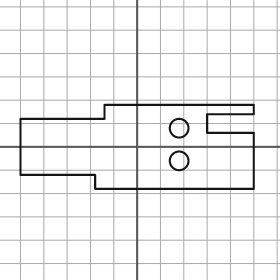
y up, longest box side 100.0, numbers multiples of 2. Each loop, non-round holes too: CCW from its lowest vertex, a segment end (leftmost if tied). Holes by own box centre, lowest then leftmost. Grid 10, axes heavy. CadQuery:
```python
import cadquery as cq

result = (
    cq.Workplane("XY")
    .moveTo(-18.0, -18.0)
    .lineTo(50.0, -18.0)
    .lineTo(50.0, 6.0)
    .lineTo(30.0, 6.0)
    .lineTo(30.0, 14.0)
    .lineTo(50.0, 14.0)
    .lineTo(50.0, 18.0)
    .lineTo(-14.0, 18.0)
    .lineTo(-14.0, 12.0)
    .lineTo(-50.0, 12.0)
    .lineTo(-50.0, -12.0)
    .lineTo(-18.0, -12.0)
    .close()
    .moveTo(18.0, -6.0)
    .circle(4.0)
    .moveTo(18.0, 8.0)
    .circle(4.0)
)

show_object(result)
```